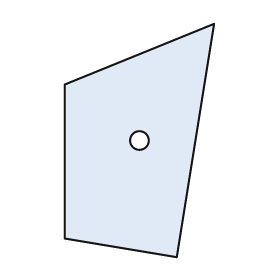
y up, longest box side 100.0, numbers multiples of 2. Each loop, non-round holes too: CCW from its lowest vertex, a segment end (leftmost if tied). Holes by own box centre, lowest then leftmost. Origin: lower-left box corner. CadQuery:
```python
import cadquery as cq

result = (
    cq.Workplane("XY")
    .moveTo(48.0, 0.0)
    .lineTo(64.0, 100.0)
    .lineTo(0.0, 74.0)
    .lineTo(0.0, 8.0)
    .close()
    .moveTo(32.0, 50.0)
    .circle(4.0)
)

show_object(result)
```